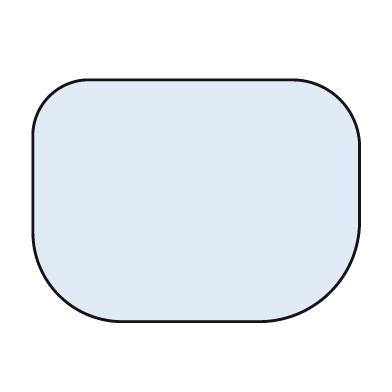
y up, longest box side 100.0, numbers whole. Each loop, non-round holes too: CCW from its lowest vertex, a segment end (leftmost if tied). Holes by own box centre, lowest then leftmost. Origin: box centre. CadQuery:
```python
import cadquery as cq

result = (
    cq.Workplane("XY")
    .moveTo(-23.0, -37.0)
    .lineTo(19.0, -37.0)
    .threePointArc((41.0, -28.0), (50.0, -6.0))
    .lineTo(50.0, 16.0)
    .threePointArc((44.0, 31.0), (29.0, 37.0))
    .lineTo(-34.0, 37.0)
    .threePointArc((-45.0, 32.0), (-50.0, 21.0))
    .lineTo(-50.0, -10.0)
    .threePointArc((-42.0, -29.0), (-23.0, -37.0))
    .close()
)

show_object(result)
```